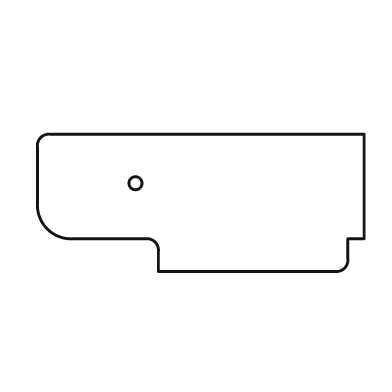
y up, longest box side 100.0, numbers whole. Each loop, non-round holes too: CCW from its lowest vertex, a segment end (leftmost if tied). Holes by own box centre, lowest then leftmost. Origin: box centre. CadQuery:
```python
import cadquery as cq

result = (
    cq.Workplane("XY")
    .moveTo(-13.0, -21.0)
    .lineTo(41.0, -21.0)
    .threePointArc((44.0, -20.0), (45.0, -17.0))
    .lineTo(45.0, -11.0)
    .lineTo(50.0, -11.0)
    .lineTo(50.0, 21.0)
    .lineTo(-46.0, 21.0)
    .threePointArc((-49.0, 20.0), (-50.0, 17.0))
    .lineTo(-50.0, 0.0)
    .threePointArc((-47.0, -8.0), (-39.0, -11.0))
    .lineTo(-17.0, -11.0)
    .threePointArc((-14.0, -12.0), (-13.0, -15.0))
    .close()
    .moveTo(-20.0, 6.0)
    .circle(2.0)
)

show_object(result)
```